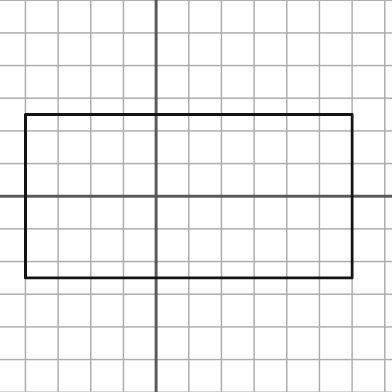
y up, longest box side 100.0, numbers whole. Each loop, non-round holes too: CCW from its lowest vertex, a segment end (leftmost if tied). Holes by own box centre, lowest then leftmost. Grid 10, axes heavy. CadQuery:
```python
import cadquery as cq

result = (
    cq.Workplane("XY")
    .moveTo(-40.0, -25.0)
    .lineTo(60.0, -25.0)
    .lineTo(60.0, 25.0)
    .lineTo(-40.0, 25.0)
    .close()
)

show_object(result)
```